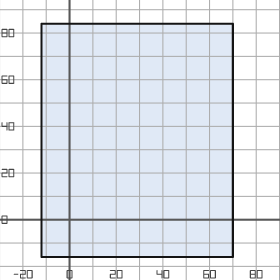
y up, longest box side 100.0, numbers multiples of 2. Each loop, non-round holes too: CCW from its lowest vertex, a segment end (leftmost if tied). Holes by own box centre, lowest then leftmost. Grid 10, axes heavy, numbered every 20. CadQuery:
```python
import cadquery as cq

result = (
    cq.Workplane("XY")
    .moveTo(-12.0, -16.0)
    .lineTo(70.0, -16.0)
    .lineTo(70.0, 84.0)
    .lineTo(-12.0, 84.0)
    .close()
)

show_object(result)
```